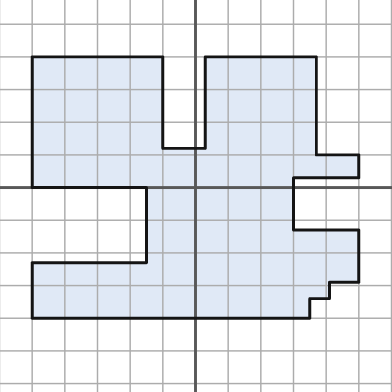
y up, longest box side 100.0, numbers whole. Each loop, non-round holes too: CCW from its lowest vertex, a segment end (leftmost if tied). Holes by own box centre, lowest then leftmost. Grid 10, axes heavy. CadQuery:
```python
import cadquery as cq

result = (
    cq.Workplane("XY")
    .moveTo(-50.0, -40.0)
    .lineTo(35.0, -40.0)
    .lineTo(35.0, -34.0)
    .lineTo(41.0, -34.0)
    .lineTo(41.0, -29.0)
    .lineTo(50.0, -29.0)
    .lineTo(50.0, -13.0)
    .lineTo(30.0, -13.0)
    .lineTo(30.0, 3.0)
    .lineTo(50.0, 3.0)
    .lineTo(50.0, 10.0)
    .lineTo(37.0, 10.0)
    .lineTo(37.0, 40.0)
    .lineTo(3.0, 40.0)
    .lineTo(3.0, 12.0)
    .lineTo(-10.0, 12.0)
    .lineTo(-10.0, 40.0)
    .lineTo(-50.0, 40.0)
    .lineTo(-50.0, 0.0)
    .lineTo(-15.0, 0.0)
    .lineTo(-15.0, -23.0)
    .lineTo(-50.0, -23.0)
    .close()
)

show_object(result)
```